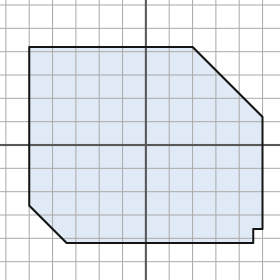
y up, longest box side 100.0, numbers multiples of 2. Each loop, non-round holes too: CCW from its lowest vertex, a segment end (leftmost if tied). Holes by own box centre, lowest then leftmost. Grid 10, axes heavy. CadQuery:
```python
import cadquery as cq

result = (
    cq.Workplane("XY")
    .moveTo(-34.0, -42.0)
    .lineTo(46.0, -42.0)
    .lineTo(46.0, -36.0)
    .lineTo(50.0, -36.0)
    .lineTo(50.0, 12.0)
    .lineTo(20.0, 42.0)
    .lineTo(-50.0, 42.0)
    .lineTo(-50.0, -26.0)
    .close()
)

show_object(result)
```